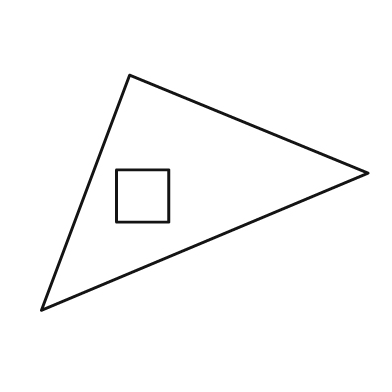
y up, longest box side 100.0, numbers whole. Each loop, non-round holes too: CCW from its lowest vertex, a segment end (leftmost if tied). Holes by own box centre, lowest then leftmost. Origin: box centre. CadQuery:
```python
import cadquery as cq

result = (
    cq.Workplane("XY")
    .moveTo(-50.0, -36.0)
    .lineTo(50.0, 6.0)
    .lineTo(-23.0, 36.0)
    .close()
    .moveTo(-27.0, -9.0)
    .lineTo(-11.0, -9.0)
    .lineTo(-11.0, 7.0)
    .lineTo(-27.0, 7.0)
    .close()
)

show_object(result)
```